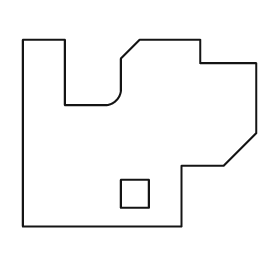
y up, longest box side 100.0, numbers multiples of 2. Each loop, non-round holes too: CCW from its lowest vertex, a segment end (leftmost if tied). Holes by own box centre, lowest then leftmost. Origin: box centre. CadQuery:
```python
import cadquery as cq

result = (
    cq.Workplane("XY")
    .moveTo(-50.0, -40.0)
    .lineTo(18.0, -40.0)
    .lineTo(18.0, -14.0)
    .lineTo(36.0, -14.0)
    .lineTo(50.0, 0.0)
    .lineTo(50.0, 30.0)
    .lineTo(26.0, 30.0)
    .lineTo(26.0, 40.0)
    .lineTo(0.0, 40.0)
    .lineTo(-8.0, 32.0)
    .lineTo(-8.0, 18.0)
    .threePointArc((-10.0, 14.0), (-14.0, 12.0))
    .lineTo(-32.0, 12.0)
    .lineTo(-32.0, 40.0)
    .lineTo(-50.0, 40.0)
    .close()
    .moveTo(-8.0, -32.0)
    .lineTo(4.0, -32.0)
    .lineTo(4.0, -20.0)
    .lineTo(-8.0, -20.0)
    .close()
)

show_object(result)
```